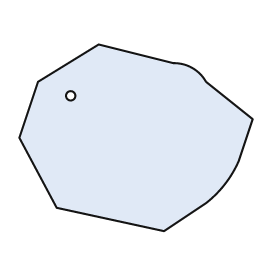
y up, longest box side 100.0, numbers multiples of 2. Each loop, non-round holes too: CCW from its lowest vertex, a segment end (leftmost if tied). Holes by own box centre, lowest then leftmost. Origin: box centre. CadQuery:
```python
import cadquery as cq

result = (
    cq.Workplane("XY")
    .moveTo(12.0, -40.0)
    .lineTo(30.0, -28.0)
    .threePointArc((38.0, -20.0), (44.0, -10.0))
    .lineTo(50.0, 8.0)
    .lineTo(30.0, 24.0)
    .threePointArc((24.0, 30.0), (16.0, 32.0))
    .lineTo(-16.0, 40.0)
    .lineTo(-42.0, 24.0)
    .lineTo(-50.0, 0.0)
    .lineTo(-34.0, -30.0)
    .close()
    .moveTo(-28.0, 18.0)
    .circle(2.0)
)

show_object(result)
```